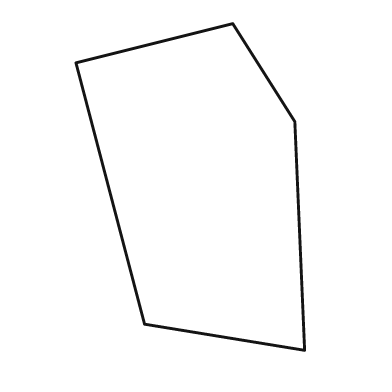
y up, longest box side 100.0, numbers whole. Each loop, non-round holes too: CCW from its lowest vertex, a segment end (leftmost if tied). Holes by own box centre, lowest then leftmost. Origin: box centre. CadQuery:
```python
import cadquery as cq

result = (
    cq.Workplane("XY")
    .moveTo(35.0, -50.0)
    .lineTo(32.0, 20.0)
    .lineTo(13.0, 50.0)
    .lineTo(-35.0, 38.0)
    .lineTo(-14.0, -42.0)
    .close()
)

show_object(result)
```